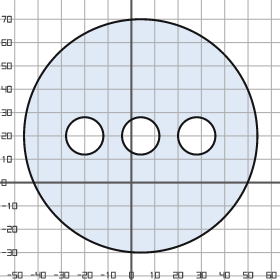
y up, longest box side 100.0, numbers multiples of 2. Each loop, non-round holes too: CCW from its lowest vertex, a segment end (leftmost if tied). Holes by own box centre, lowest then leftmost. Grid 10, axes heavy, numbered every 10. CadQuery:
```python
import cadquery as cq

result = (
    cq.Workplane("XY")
    .moveTo(4.0, 20.0)
    .circle(50.0)
    .moveTo(-20.0, 20.0)
    .circle(8.0)
    .moveTo(4.0, 20.0)
    .circle(8.0)
    .moveTo(28.0, 20.0)
    .circle(8.0)
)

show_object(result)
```